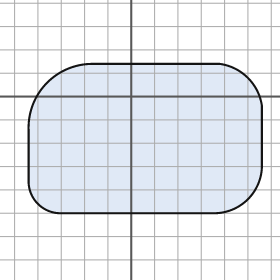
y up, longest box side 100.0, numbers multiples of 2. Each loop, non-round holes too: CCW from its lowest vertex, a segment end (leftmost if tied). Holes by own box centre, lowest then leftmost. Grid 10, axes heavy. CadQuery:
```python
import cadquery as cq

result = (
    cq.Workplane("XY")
    .moveTo(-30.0, -50.0)
    .lineTo(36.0, -50.0)
    .threePointArc((50.0, -44.0), (56.0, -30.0))
    .lineTo(56.0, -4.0)
    .threePointArc((50.0, 8.0), (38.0, 14.0))
    .lineTo(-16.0, 14.0)
    .threePointArc((-36.0, 6.0), (-44.0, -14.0))
    .lineTo(-44.0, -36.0)
    .threePointArc((-40.0, -46.0), (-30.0, -50.0))
    .close()
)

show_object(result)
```